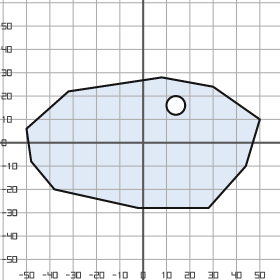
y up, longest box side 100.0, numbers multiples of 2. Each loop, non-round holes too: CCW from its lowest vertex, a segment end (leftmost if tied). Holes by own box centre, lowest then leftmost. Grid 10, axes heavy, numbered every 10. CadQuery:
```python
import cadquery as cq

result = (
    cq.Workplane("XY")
    .moveTo(-2.0, -28.0)
    .lineTo(28.0, -28.0)
    .lineTo(44.0, -10.0)
    .lineTo(50.0, 10.0)
    .lineTo(30.0, 24.0)
    .lineTo(8.0, 28.0)
    .lineTo(-32.0, 22.0)
    .lineTo(-50.0, 6.0)
    .lineTo(-48.0, -8.0)
    .lineTo(-38.0, -20.0)
    .close()
    .moveTo(14.0, 16.0)
    .circle(4.0)
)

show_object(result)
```